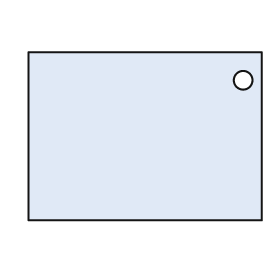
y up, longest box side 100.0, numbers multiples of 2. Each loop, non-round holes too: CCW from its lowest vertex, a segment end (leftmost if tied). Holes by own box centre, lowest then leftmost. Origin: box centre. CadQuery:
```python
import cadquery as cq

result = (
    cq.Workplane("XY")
    .moveTo(-50.0, -36.0)
    .lineTo(50.0, -36.0)
    .lineTo(50.0, 36.0)
    .lineTo(-50.0, 36.0)
    .close()
    .moveTo(42.0, 24.0)
    .circle(4.0)
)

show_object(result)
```